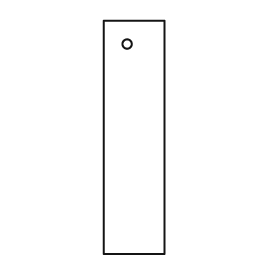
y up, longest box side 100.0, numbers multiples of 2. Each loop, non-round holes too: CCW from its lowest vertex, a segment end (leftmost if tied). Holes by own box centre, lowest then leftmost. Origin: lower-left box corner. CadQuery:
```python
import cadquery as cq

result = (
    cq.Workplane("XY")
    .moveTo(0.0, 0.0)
    .lineTo(26.0, 0.0)
    .lineTo(26.0, 100.0)
    .lineTo(0.0, 100.0)
    .close()
    .moveTo(10.0, 90.0)
    .circle(2.0)
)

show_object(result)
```